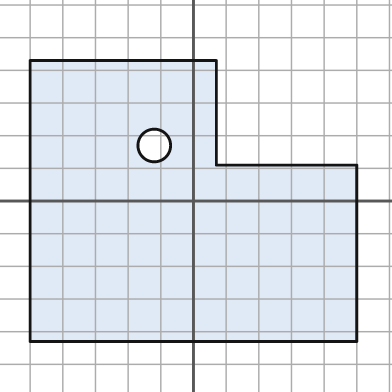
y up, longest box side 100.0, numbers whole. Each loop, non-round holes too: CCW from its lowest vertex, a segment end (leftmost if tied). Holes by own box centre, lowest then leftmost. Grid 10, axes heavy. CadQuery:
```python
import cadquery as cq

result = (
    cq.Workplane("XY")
    .moveTo(-50.0, -43.0)
    .lineTo(50.0, -43.0)
    .lineTo(50.0, 11.0)
    .lineTo(7.0, 11.0)
    .lineTo(7.0, 43.0)
    .lineTo(-50.0, 43.0)
    .close()
    .moveTo(-12.0, 17.0)
    .circle(5.0)
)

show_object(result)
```